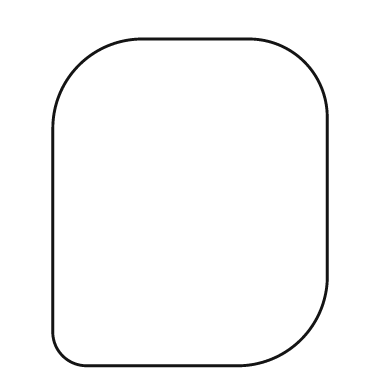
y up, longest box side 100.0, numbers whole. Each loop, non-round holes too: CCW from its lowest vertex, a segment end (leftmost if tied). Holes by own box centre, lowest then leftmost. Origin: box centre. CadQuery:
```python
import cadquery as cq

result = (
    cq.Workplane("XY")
    .moveTo(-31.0, -50.0)
    .lineTo(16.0, -50.0)
    .threePointArc((34.0, -42.0), (42.0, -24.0))
    .lineTo(42.0, 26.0)
    .threePointArc((35.0, 43.0), (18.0, 50.0))
    .lineTo(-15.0, 50.0)
    .threePointArc((-34.0, 42.0), (-42.0, 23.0))
    .lineTo(-42.0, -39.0)
    .threePointArc((-39.0, -47.0), (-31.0, -50.0))
    .close()
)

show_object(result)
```